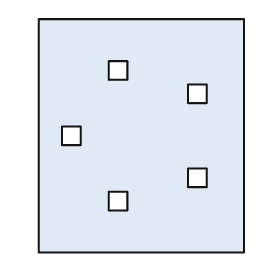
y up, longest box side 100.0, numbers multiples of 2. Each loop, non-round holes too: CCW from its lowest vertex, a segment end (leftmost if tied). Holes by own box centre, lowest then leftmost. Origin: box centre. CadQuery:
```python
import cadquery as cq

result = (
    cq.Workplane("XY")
    .moveTo(-44.0, -50.0)
    .lineTo(44.0, -50.0)
    .lineTo(44.0, 50.0)
    .lineTo(-44.0, 50.0)
    .close()
    .moveTo(-14.0, -32.0)
    .lineTo(-6.0, -32.0)
    .lineTo(-6.0, -24.0)
    .lineTo(-14.0, -24.0)
    .close()
    .moveTo(20.0, -22.0)
    .lineTo(28.0, -22.0)
    .lineTo(28.0, -14.0)
    .lineTo(20.0, -14.0)
    .close()
    .moveTo(-34.0, -4.0)
    .lineTo(-26.0, -4.0)
    .lineTo(-26.0, 4.0)
    .lineTo(-34.0, 4.0)
    .close()
    .moveTo(20.0, 14.0)
    .lineTo(28.0, 14.0)
    .lineTo(28.0, 22.0)
    .lineTo(20.0, 22.0)
    .close()
    .moveTo(-14.0, 24.0)
    .lineTo(-6.0, 24.0)
    .lineTo(-6.0, 32.0)
    .lineTo(-14.0, 32.0)
    .close()
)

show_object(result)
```